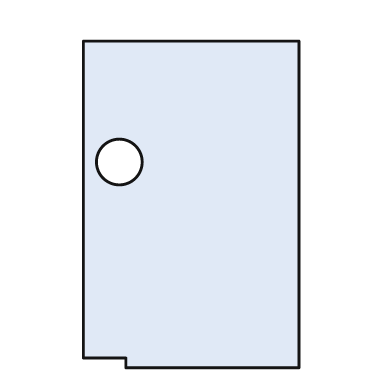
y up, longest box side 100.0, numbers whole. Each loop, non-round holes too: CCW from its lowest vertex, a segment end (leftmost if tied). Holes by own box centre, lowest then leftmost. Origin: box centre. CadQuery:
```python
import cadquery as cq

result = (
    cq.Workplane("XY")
    .moveTo(-20.0, -50.0)
    .lineTo(33.0, -50.0)
    .lineTo(33.0, 50.0)
    .lineTo(-33.0, 50.0)
    .lineTo(-33.0, -47.0)
    .lineTo(-20.0, -47.0)
    .close()
    .moveTo(-22.0, 13.0)
    .circle(7.0)
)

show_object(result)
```